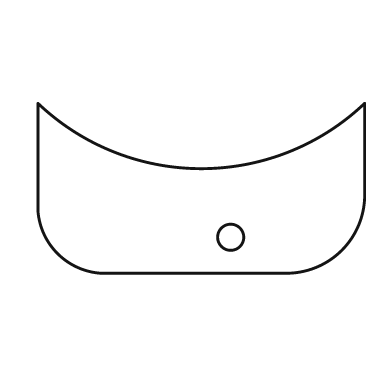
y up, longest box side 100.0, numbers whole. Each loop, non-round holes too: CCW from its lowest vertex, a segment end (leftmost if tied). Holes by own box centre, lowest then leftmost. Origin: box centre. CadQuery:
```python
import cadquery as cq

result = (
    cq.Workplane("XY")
    .moveTo(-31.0, -26.0)
    .lineTo(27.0, -26.0)
    .threePointArc((43.0, -19.0), (50.0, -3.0))
    .lineTo(50.0, 26.0)
    .threePointArc((0.0, 6.0), (-50.0, 26.0))
    .lineTo(-50.0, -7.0)
    .threePointArc((-44.0, -20.0), (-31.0, -26.0))
    .close()
    .moveTo(9.0, -15.0)
    .circle(4.0)
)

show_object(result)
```